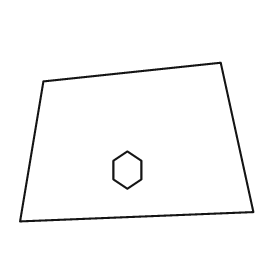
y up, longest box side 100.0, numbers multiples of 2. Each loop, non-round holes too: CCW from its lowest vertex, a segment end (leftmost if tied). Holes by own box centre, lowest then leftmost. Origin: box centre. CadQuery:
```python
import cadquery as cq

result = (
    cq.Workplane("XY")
    .moveTo(-50.0, -34.0)
    .lineTo(50.0, -30.0)
    .lineTo(36.0, 34.0)
    .lineTo(-40.0, 26.0)
    .close()
    .moveTo(-4.0, -20.0)
    .lineTo(2.0, -16.0)
    .lineTo(2.0, -8.0)
    .lineTo(-4.0, -4.0)
    .lineTo(-10.0, -8.0)
    .lineTo(-10.0, -16.0)
    .close()
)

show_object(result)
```